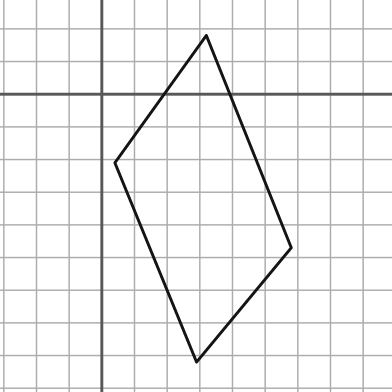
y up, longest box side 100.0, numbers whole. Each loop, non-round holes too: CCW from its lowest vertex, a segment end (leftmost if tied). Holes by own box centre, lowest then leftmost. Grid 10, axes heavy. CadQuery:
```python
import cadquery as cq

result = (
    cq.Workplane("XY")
    .moveTo(29.0, -82.0)
    .lineTo(58.0, -47.0)
    .lineTo(32.0, 18.0)
    .lineTo(4.0, -21.0)
    .close()
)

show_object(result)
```